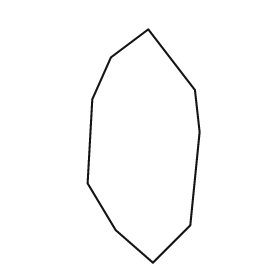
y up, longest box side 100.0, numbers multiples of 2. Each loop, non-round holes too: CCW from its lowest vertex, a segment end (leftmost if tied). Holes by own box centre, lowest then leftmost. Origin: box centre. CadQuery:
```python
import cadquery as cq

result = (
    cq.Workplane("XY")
    .moveTo(4.0, -50.0)
    .lineTo(20.0, -34.0)
    .lineTo(24.0, 6.0)
    .lineTo(22.0, 24.0)
    .lineTo(2.0, 50.0)
    .lineTo(-14.0, 38.0)
    .lineTo(-22.0, 20.0)
    .lineTo(-24.0, -16.0)
    .lineTo(-12.0, -36.0)
    .close()
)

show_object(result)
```